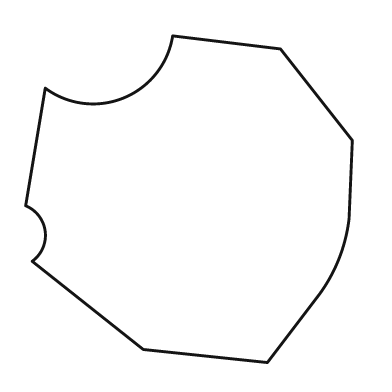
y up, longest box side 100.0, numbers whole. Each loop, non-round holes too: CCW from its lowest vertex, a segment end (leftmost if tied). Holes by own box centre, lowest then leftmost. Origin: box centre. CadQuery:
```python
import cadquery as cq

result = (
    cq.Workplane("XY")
    .moveTo(24.0, -50.0)
    .lineTo(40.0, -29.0)
    .threePointArc((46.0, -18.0), (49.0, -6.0))
    .lineTo(50.0, 18.0)
    .lineTo(28.0, 46.0)
    .lineTo(-5.0, 50.0)
    .threePointArc((-20.0, 31.0), (-44.0, 34.0))
    .lineTo(-50.0, -2.0)
    .threePointArc((-44.0, -10.0), (-48.0, -19.0))
    .lineTo(-14.0, -46.0)
    .close()
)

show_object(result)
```